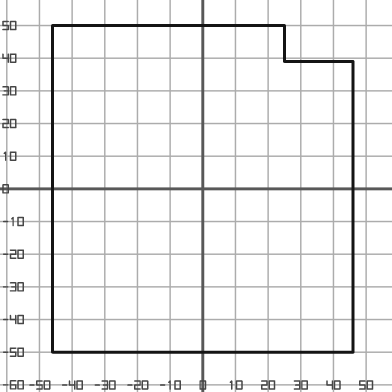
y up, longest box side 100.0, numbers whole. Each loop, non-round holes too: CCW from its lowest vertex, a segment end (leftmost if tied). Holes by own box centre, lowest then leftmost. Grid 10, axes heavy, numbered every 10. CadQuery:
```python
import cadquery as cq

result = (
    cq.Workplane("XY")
    .moveTo(-46.0, -50.0)
    .lineTo(46.0, -50.0)
    .lineTo(46.0, 39.0)
    .lineTo(25.0, 39.0)
    .lineTo(25.0, 50.0)
    .lineTo(-46.0, 50.0)
    .close()
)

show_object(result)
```